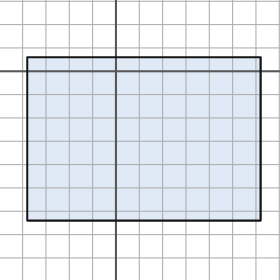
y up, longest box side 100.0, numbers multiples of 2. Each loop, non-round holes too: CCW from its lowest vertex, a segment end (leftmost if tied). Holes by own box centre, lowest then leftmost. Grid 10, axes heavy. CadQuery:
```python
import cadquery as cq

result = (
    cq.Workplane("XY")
    .moveTo(-38.0, -64.0)
    .lineTo(62.0, -64.0)
    .lineTo(62.0, 6.0)
    .lineTo(-38.0, 6.0)
    .close()
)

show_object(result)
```